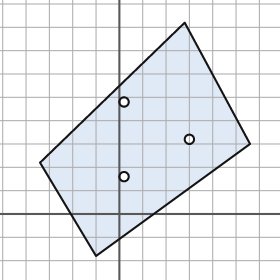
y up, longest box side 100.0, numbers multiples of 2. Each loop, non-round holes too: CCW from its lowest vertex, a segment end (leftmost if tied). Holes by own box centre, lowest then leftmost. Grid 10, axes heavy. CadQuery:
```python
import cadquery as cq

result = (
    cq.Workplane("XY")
    .moveTo(-10.0, -18.0)
    .lineTo(56.0, 30.0)
    .lineTo(28.0, 82.0)
    .lineTo(-34.0, 22.0)
    .close()
    .moveTo(2.0, 16.0)
    .circle(2.0)
    .moveTo(30.0, 32.0)
    .circle(2.0)
    .moveTo(2.0, 48.0)
    .circle(2.0)
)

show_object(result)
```